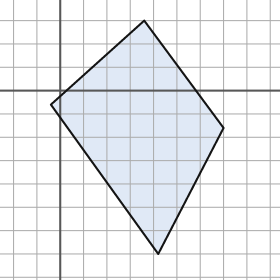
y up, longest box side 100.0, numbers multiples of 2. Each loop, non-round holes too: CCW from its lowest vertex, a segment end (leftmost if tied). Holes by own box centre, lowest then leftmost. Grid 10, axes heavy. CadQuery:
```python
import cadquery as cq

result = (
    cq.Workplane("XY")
    .moveTo(42.0, -70.0)
    .lineTo(70.0, -16.0)
    .lineTo(36.0, 30.0)
    .lineTo(-4.0, -6.0)
    .close()
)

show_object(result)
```